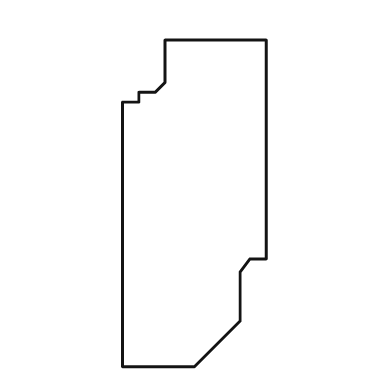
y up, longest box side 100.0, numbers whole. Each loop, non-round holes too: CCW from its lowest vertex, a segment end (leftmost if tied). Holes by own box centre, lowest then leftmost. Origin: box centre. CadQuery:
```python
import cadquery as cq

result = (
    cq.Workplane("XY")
    .moveTo(-22.0, -50.0)
    .lineTo(0.0, -50.0)
    .lineTo(14.0, -36.0)
    .lineTo(14.0, -21.0)
    .lineTo(17.0, -17.0)
    .lineTo(22.0, -17.0)
    .lineTo(22.0, 50.0)
    .lineTo(-9.0, 50.0)
    .lineTo(-9.0, 37.0)
    .lineTo(-12.0, 34.0)
    .lineTo(-17.0, 34.0)
    .lineTo(-17.0, 31.0)
    .lineTo(-22.0, 31.0)
    .close()
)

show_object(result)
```